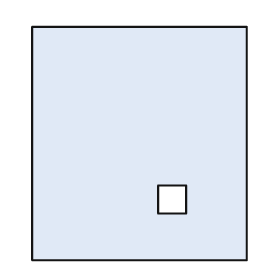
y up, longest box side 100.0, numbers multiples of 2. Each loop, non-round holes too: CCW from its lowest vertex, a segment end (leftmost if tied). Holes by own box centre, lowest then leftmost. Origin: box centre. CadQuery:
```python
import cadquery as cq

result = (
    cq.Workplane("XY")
    .moveTo(-46.0, -50.0)
    .lineTo(46.0, -50.0)
    .lineTo(46.0, 50.0)
    .lineTo(-46.0, 50.0)
    .close()
    .moveTo(8.0, -30.0)
    .lineTo(20.0, -30.0)
    .lineTo(20.0, -18.0)
    .lineTo(8.0, -18.0)
    .close()
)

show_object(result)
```